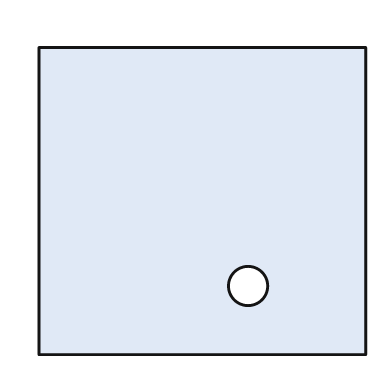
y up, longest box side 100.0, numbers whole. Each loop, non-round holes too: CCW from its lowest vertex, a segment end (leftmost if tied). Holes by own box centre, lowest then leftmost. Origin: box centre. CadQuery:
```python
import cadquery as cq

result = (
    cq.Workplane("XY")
    .moveTo(-50.0, -47.0)
    .lineTo(50.0, -47.0)
    .lineTo(50.0, 47.0)
    .lineTo(-50.0, 47.0)
    .close()
    .moveTo(14.0, -26.0)
    .circle(6.0)
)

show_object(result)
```